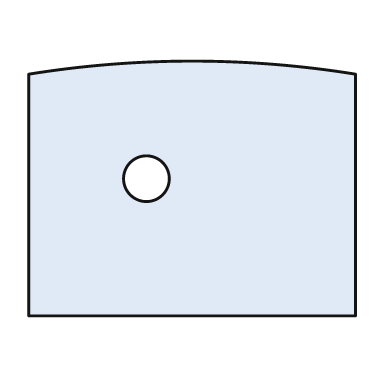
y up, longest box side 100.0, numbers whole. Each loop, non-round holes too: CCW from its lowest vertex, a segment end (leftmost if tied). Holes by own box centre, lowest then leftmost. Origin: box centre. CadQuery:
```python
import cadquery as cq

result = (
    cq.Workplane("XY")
    .moveTo(-50.0, -39.0)
    .lineTo(50.0, -39.0)
    .lineTo(50.0, 35.0)
    .threePointArc((0.0, 39.0), (-50.0, 35.0))
    .close()
    .moveTo(-14.0, 3.0)
    .circle(7.0)
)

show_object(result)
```